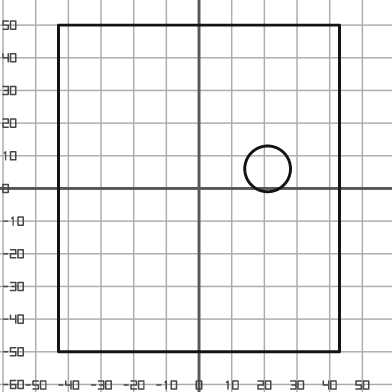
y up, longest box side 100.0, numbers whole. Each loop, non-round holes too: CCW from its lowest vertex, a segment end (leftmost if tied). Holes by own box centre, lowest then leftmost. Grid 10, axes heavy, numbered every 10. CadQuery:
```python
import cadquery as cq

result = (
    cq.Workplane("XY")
    .moveTo(-43.0, -50.0)
    .lineTo(43.0, -50.0)
    .lineTo(43.0, 50.0)
    .lineTo(-43.0, 50.0)
    .close()
    .moveTo(21.0, 6.0)
    .circle(7.0)
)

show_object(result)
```